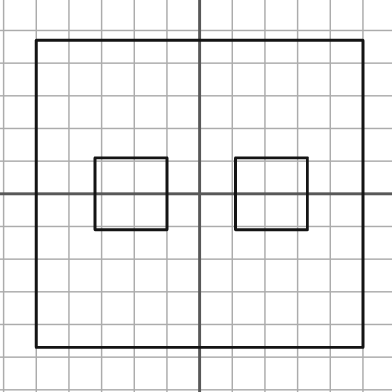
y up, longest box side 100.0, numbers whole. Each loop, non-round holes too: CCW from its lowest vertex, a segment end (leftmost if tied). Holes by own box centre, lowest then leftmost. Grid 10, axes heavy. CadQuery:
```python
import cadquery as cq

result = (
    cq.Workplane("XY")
    .moveTo(-50.0, -47.0)
    .lineTo(50.0, -47.0)
    .lineTo(50.0, 47.0)
    .lineTo(-50.0, 47.0)
    .close()
    .moveTo(-32.0, -11.0)
    .lineTo(-10.0, -11.0)
    .lineTo(-10.0, 11.0)
    .lineTo(-32.0, 11.0)
    .close()
    .moveTo(11.0, -11.0)
    .lineTo(33.0, -11.0)
    .lineTo(33.0, 11.0)
    .lineTo(11.0, 11.0)
    .close()
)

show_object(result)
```